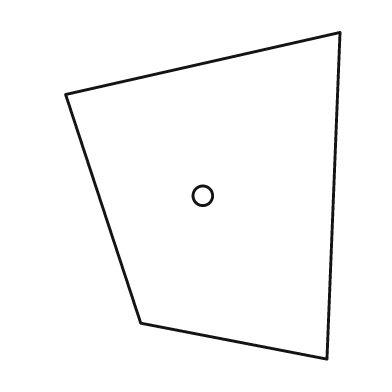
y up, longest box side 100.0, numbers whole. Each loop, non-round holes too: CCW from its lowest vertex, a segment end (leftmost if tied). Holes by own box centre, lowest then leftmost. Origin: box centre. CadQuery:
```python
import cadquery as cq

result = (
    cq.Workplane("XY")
    .moveTo(38.0, -50.0)
    .lineTo(42.0, 50.0)
    .lineTo(-42.0, 31.0)
    .lineTo(-19.0, -39.0)
    .close()
    .moveTo(0.0, 0.0)
    .circle(3.0)
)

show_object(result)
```